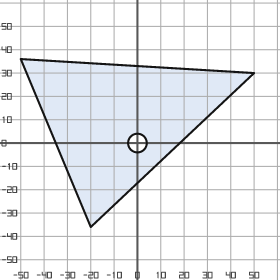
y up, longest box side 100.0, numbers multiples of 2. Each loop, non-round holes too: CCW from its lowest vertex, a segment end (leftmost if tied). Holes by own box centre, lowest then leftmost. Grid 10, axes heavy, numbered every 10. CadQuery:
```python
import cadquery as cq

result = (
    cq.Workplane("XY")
    .moveTo(-20.0, -36.0)
    .lineTo(50.0, 30.0)
    .lineTo(-50.0, 36.0)
    .close()
    .moveTo(0.0, 0.0)
    .circle(4.0)
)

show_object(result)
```